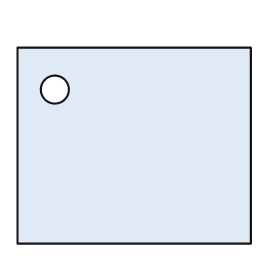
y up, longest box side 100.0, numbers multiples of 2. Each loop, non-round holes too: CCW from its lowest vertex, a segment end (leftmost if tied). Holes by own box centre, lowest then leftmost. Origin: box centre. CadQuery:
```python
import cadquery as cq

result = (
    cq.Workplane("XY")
    .moveTo(-50.0, -42.0)
    .lineTo(50.0, -42.0)
    .lineTo(50.0, 42.0)
    .lineTo(-50.0, 42.0)
    .close()
    .moveTo(-34.0, 24.0)
    .circle(6.0)
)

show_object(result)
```